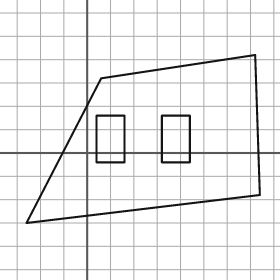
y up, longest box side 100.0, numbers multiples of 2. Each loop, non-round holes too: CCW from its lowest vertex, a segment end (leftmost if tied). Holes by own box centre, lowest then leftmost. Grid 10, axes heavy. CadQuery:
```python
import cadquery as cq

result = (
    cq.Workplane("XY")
    .moveTo(-26.0, -30.0)
    .lineTo(74.0, -18.0)
    .lineTo(72.0, 42.0)
    .lineTo(6.0, 32.0)
    .close()
    .moveTo(4.0, -4.0)
    .lineTo(16.0, -4.0)
    .lineTo(16.0, 16.0)
    .lineTo(4.0, 16.0)
    .close()
    .moveTo(32.0, -4.0)
    .lineTo(44.0, -4.0)
    .lineTo(44.0, 16.0)
    .lineTo(32.0, 16.0)
    .close()
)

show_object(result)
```